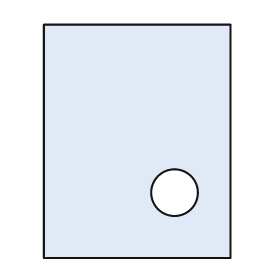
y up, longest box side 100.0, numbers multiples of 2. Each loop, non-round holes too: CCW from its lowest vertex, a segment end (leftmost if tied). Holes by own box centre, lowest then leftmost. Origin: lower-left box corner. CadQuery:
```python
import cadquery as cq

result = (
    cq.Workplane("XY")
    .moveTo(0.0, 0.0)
    .lineTo(80.0, 0.0)
    .lineTo(80.0, 100.0)
    .lineTo(0.0, 100.0)
    .close()
    .moveTo(56.0, 28.0)
    .circle(10.0)
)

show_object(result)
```